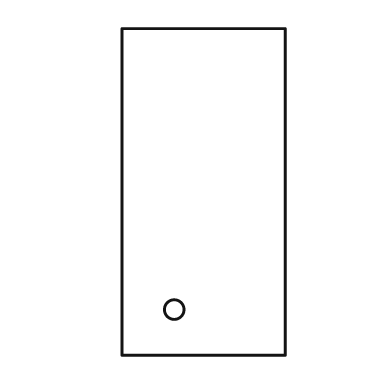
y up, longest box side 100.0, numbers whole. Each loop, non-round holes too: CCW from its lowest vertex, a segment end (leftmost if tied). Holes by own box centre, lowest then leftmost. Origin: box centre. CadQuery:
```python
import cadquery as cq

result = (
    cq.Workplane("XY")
    .moveTo(-25.0, -50.0)
    .lineTo(25.0, -50.0)
    .lineTo(25.0, 50.0)
    .lineTo(-25.0, 50.0)
    .close()
    .moveTo(-9.0, -36.0)
    .circle(3.0)
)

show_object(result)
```